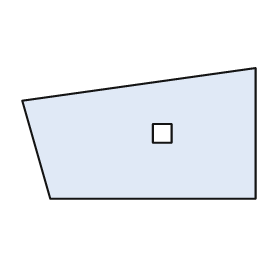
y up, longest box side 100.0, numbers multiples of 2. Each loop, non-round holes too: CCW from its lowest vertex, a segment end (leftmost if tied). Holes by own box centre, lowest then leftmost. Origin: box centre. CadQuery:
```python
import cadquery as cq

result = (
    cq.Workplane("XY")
    .moveTo(-38.0, -28.0)
    .lineTo(50.0, -28.0)
    .lineTo(50.0, 28.0)
    .lineTo(-50.0, 14.0)
    .close()
    .moveTo(6.0, -4.0)
    .lineTo(14.0, -4.0)
    .lineTo(14.0, 4.0)
    .lineTo(6.0, 4.0)
    .close()
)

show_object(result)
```